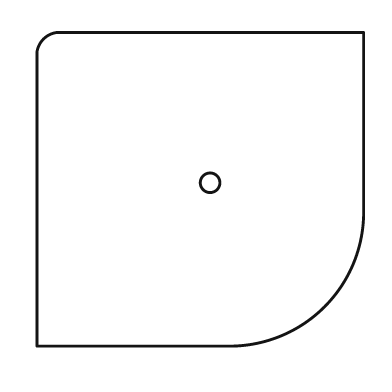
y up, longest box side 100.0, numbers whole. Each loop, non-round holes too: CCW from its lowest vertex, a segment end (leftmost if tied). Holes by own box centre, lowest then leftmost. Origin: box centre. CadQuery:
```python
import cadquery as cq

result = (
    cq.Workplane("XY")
    .moveTo(-50.0, -48.0)
    .lineTo(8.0, -48.0)
    .threePointArc((38.0, -36.0), (50.0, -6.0))
    .lineTo(50.0, 48.0)
    .lineTo(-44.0, 48.0)
    .threePointArc((-48.0, 46.0), (-50.0, 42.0))
    .close()
    .moveTo(3.0, 2.0)
    .circle(3.0)
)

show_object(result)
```